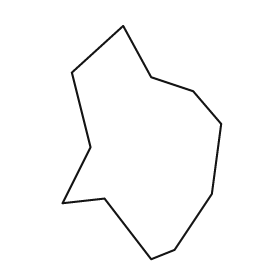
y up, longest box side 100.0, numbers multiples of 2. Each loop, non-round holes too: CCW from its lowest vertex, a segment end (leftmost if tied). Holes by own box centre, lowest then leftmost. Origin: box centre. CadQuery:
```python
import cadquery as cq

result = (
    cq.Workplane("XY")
    .moveTo(4.0, -50.0)
    .lineTo(14.0, -46.0)
    .lineTo(30.0, -22.0)
    .lineTo(34.0, 8.0)
    .lineTo(22.0, 22.0)
    .lineTo(4.0, 28.0)
    .lineTo(-8.0, 50.0)
    .lineTo(-30.0, 30.0)
    .lineTo(-22.0, -2.0)
    .lineTo(-34.0, -26.0)
    .lineTo(-16.0, -24.0)
    .close()
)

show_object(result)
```